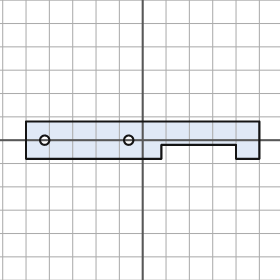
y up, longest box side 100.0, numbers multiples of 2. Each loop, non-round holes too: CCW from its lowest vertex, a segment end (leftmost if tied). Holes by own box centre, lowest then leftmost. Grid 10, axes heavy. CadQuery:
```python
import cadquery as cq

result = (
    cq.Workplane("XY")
    .moveTo(-50.0, -8.0)
    .lineTo(8.0, -8.0)
    .lineTo(8.0, -2.0)
    .lineTo(40.0, -2.0)
    .lineTo(40.0, -8.0)
    .lineTo(50.0, -8.0)
    .lineTo(50.0, 8.0)
    .lineTo(-50.0, 8.0)
    .close()
    .moveTo(-42.0, 0.0)
    .circle(2.0)
    .moveTo(-6.0, 0.0)
    .circle(2.0)
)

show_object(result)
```